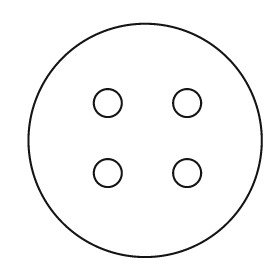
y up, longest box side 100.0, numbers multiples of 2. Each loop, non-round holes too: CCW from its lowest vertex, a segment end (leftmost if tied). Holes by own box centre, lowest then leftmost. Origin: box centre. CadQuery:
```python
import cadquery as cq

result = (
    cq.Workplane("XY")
    .moveTo(0.0, 0.0)
    .circle(50.0)
    .moveTo(-16.0, -14.0)
    .circle(6.0)
    .moveTo(18.0, -14.0)
    .circle(6.0)
    .moveTo(-16.0, 16.0)
    .circle(6.0)
    .moveTo(18.0, 16.0)
    .circle(6.0)
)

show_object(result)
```